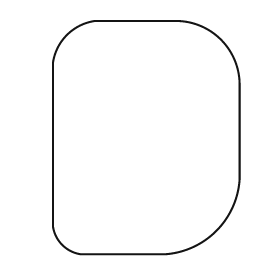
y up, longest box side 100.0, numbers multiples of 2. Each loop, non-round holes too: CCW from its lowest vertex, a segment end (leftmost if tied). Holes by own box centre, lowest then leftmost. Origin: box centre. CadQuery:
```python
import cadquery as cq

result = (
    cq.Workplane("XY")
    .moveTo(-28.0, -50.0)
    .lineTo(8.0, -50.0)
    .threePointArc((30.0, -40.0), (40.0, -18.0))
    .lineTo(40.0, 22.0)
    .threePointArc((32.0, 42.0), (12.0, 50.0))
    .lineTo(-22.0, 50.0)
    .threePointArc((-34.0, 44.0), (-40.0, 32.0))
    .lineTo(-40.0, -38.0)
    .threePointArc((-36.0, -46.0), (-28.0, -50.0))
    .close()
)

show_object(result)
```